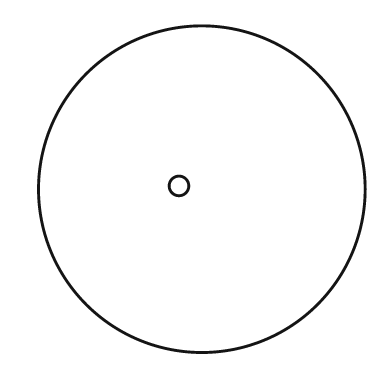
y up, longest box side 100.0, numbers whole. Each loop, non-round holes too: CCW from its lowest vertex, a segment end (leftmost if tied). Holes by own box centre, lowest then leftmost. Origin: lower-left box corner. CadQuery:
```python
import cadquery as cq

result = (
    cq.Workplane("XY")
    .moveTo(50.0, 50.0)
    .circle(50.0)
    .moveTo(43.0, 51.0)
    .circle(3.0)
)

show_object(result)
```